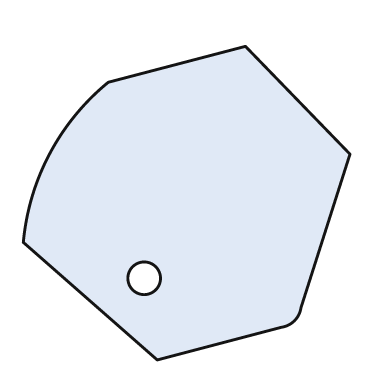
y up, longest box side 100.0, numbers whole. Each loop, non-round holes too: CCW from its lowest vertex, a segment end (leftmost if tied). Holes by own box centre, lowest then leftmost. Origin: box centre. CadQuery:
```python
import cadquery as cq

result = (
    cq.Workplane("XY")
    .moveTo(-9.0, -48.0)
    .lineTo(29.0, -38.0)
    .threePointArc((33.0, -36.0), (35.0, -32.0))
    .lineTo(50.0, 15.0)
    .lineTo(18.0, 48.0)
    .lineTo(-24.0, 37.0)
    .threePointArc((-42.0, 15.0), (-50.0, -12.0))
    .close()
    .moveTo(-13.0, -23.0)
    .circle(5.0)
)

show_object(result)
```